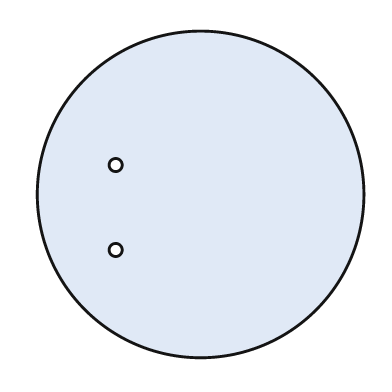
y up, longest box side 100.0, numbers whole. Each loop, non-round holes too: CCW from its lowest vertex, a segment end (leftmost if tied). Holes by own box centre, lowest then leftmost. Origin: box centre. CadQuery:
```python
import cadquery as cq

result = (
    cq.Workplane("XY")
    .moveTo(0.0, 0.0)
    .circle(50.0)
    .moveTo(-26.0, -17.0)
    .circle(2.0)
    .moveTo(-26.0, 9.0)
    .circle(2.0)
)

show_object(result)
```